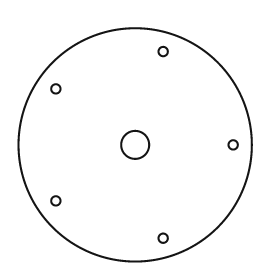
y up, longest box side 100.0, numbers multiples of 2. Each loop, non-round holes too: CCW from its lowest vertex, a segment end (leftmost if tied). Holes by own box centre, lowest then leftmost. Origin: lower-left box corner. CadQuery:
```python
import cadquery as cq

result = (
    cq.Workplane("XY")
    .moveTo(50.0, 50.0)
    .circle(50.0)
    .moveTo(62.0, 10.0)
    .circle(2.0)
    .moveTo(16.0, 26.0)
    .circle(2.0)
    .moveTo(50.0, 50.0)
    .circle(6.0)
    .moveTo(92.0, 50.0)
    .circle(2.0)
    .moveTo(16.0, 74.0)
    .circle(2.0)
    .moveTo(62.0, 90.0)
    .circle(2.0)
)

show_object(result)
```